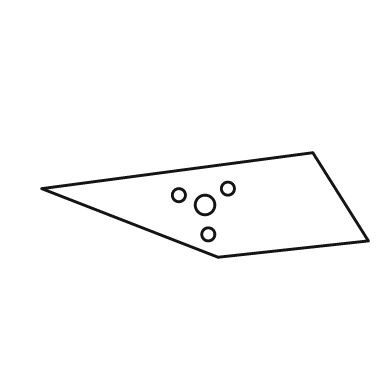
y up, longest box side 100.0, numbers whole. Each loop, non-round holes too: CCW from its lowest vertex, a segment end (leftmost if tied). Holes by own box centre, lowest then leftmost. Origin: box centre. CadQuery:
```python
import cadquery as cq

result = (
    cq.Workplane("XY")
    .moveTo(4.0, -16.0)
    .lineTo(50.0, -11.0)
    .lineTo(33.0, 16.0)
    .lineTo(-50.0, 5.0)
    .close()
    .moveTo(1.0, -9.0)
    .circle(2.0)
    .moveTo(0.0, 0.0)
    .circle(3.0)
    .moveTo(-8.0, 3.0)
    .circle(2.0)
    .moveTo(7.0, 5.0)
    .circle(2.0)
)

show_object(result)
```